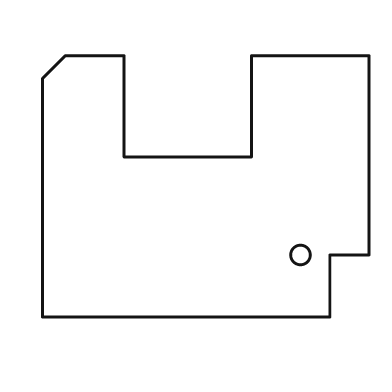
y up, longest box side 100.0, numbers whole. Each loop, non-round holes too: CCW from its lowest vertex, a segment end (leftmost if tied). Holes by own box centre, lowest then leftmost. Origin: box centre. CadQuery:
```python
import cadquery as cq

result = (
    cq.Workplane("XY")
    .moveTo(-50.0, -40.0)
    .lineTo(38.0, -40.0)
    .lineTo(38.0, -21.0)
    .lineTo(50.0, -21.0)
    .lineTo(50.0, 40.0)
    .lineTo(14.0, 40.0)
    .lineTo(14.0, 9.0)
    .lineTo(-25.0, 9.0)
    .lineTo(-25.0, 40.0)
    .lineTo(-43.0, 40.0)
    .lineTo(-50.0, 33.0)
    .close()
    .moveTo(29.0, -21.0)
    .circle(3.0)
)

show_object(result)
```